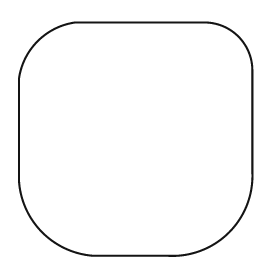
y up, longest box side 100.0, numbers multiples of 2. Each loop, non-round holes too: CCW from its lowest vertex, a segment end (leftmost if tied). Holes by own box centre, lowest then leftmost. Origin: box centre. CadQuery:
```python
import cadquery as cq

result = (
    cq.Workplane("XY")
    .moveTo(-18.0, -50.0)
    .lineTo(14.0, -50.0)
    .threePointArc((40.0, -40.0), (50.0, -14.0))
    .lineTo(50.0, 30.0)
    .threePointArc((44.0, 44.0), (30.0, 50.0))
    .lineTo(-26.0, 50.0)
    .threePointArc((-42.0, 42.0), (-50.0, 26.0))
    .lineTo(-50.0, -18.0)
    .threePointArc((-40.0, -40.0), (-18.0, -50.0))
    .close()
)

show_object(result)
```